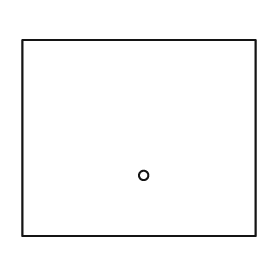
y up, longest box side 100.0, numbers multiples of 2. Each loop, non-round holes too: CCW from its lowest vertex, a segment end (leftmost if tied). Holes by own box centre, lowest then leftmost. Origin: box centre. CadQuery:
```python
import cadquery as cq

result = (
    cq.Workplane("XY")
    .moveTo(-50.0, -42.0)
    .lineTo(50.0, -42.0)
    .lineTo(50.0, 42.0)
    .lineTo(-50.0, 42.0)
    .close()
    .moveTo(2.0, -16.0)
    .circle(2.0)
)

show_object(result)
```